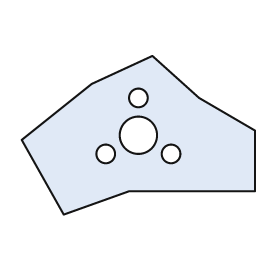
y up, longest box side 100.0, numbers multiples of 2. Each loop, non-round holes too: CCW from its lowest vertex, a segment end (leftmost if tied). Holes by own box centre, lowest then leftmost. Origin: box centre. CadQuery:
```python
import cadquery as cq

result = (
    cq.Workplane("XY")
    .moveTo(-32.0, -34.0)
    .lineTo(-4.0, -24.0)
    .lineTo(50.0, -24.0)
    .lineTo(50.0, 2.0)
    .lineTo(26.0, 16.0)
    .lineTo(6.0, 34.0)
    .lineTo(-20.0, 22.0)
    .lineTo(-50.0, -2.0)
    .close()
    .moveTo(-14.0, -8.0)
    .circle(4.0)
    .moveTo(14.0, -8.0)
    .circle(4.0)
    .moveTo(0.0, 0.0)
    .circle(8.0)
    .moveTo(0.0, 16.0)
    .circle(4.0)
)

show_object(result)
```